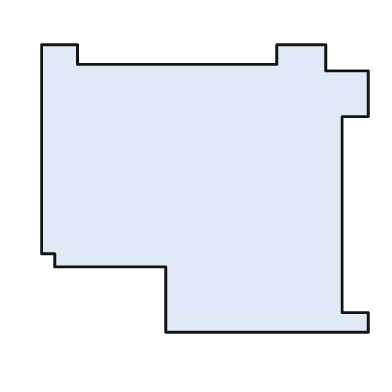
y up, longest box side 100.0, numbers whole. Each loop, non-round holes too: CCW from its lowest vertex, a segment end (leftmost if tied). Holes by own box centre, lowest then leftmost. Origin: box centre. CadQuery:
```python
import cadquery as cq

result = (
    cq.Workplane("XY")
    .moveTo(-12.0, -44.0)
    .lineTo(50.0, -44.0)
    .lineTo(50.0, -38.0)
    .lineTo(42.0, -38.0)
    .lineTo(42.0, 22.0)
    .lineTo(50.0, 22.0)
    .lineTo(50.0, 36.0)
    .lineTo(37.0, 36.0)
    .lineTo(37.0, 44.0)
    .lineTo(22.0, 44.0)
    .lineTo(22.0, 38.0)
    .lineTo(-39.0, 38.0)
    .lineTo(-39.0, 44.0)
    .lineTo(-50.0, 44.0)
    .lineTo(-50.0, -20.0)
    .lineTo(-46.0, -20.0)
    .lineTo(-46.0, -24.0)
    .lineTo(-12.0, -24.0)
    .close()
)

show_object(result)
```